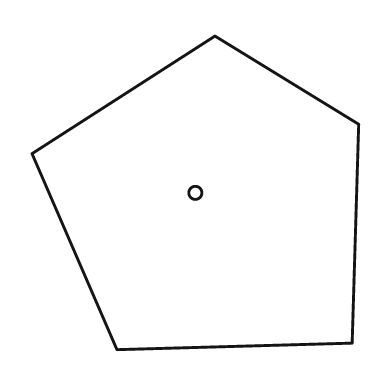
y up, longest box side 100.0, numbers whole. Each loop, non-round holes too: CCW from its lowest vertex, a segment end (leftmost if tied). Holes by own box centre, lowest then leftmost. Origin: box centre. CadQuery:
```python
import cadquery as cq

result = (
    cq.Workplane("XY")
    .moveTo(-24.0, -48.0)
    .lineTo(48.0, -46.0)
    .lineTo(50.0, 21.0)
    .lineTo(6.0, 48.0)
    .lineTo(-50.0, 12.0)
    .close()
    .moveTo(0.0, 0.0)
    .circle(2.0)
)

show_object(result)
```